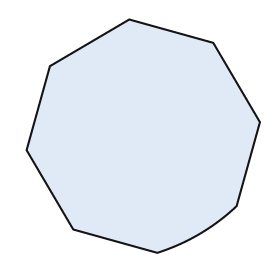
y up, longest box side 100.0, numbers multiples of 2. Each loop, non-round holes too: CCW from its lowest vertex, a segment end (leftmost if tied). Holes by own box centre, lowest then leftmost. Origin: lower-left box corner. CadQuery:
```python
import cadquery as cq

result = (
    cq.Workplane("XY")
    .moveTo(56.0, 0.0)
    .threePointArc((74.0, 8.0), (90.0, 20.0))
    .lineTo(100.0, 56.0)
    .lineTo(80.0, 90.0)
    .lineTo(44.0, 100.0)
    .lineTo(10.0, 80.0)
    .lineTo(0.0, 44.0)
    .lineTo(20.0, 10.0)
    .close()
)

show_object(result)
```